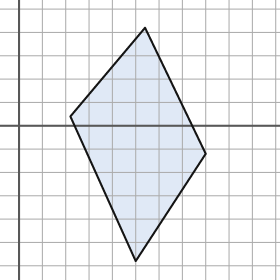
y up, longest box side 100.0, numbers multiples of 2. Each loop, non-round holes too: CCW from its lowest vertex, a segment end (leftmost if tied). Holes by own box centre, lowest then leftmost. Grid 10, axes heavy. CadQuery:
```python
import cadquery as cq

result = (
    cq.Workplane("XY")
    .moveTo(50.0, -58.0)
    .lineTo(80.0, -12.0)
    .lineTo(54.0, 42.0)
    .lineTo(22.0, 4.0)
    .close()
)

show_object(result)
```